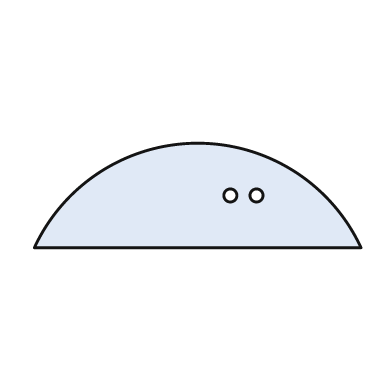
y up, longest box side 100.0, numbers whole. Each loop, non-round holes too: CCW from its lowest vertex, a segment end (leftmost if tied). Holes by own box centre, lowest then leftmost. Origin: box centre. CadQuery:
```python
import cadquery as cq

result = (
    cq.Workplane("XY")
    .moveTo(-50.0, -16.0)
    .lineTo(50.0, -16.0)
    .threePointArc((0.0, 16.0), (-50.0, -16.0))
    .close()
    .moveTo(10.0, 0.0)
    .circle(2.0)
    .moveTo(18.0, 0.0)
    .circle(2.0)
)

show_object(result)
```